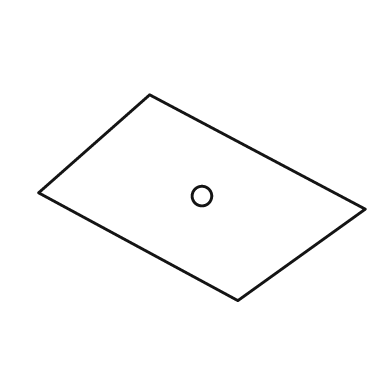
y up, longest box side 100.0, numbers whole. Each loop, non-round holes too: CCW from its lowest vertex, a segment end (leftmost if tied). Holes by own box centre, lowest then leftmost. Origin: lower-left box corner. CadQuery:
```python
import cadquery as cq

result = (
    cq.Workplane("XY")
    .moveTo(61.0, 0.0)
    .lineTo(100.0, 28.0)
    .lineTo(34.0, 63.0)
    .lineTo(0.0, 33.0)
    .close()
    .moveTo(50.0, 32.0)
    .circle(3.0)
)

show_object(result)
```